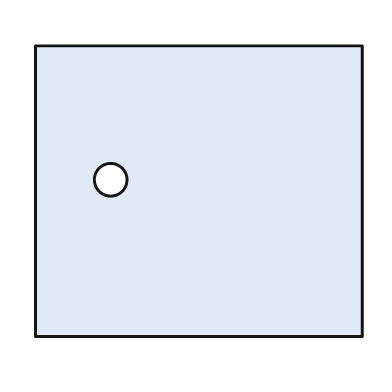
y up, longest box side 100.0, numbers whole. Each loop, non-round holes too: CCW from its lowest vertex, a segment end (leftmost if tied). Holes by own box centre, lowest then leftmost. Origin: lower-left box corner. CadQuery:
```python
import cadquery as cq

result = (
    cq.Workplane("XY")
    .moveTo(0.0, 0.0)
    .lineTo(100.0, 0.0)
    .lineTo(100.0, 89.0)
    .lineTo(0.0, 89.0)
    .close()
    .moveTo(23.0, 48.0)
    .circle(5.0)
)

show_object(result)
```